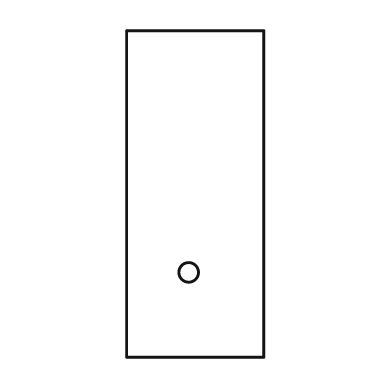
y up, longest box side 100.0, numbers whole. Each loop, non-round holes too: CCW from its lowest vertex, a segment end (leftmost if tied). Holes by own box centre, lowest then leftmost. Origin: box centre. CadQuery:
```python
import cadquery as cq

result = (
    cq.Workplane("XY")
    .moveTo(-21.0, -50.0)
    .lineTo(21.0, -50.0)
    .lineTo(21.0, 50.0)
    .lineTo(-21.0, 50.0)
    .close()
    .moveTo(-2.0, -24.0)
    .circle(3.0)
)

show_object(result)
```